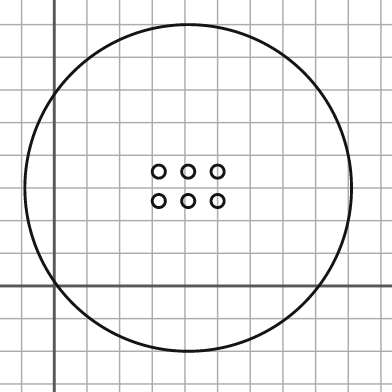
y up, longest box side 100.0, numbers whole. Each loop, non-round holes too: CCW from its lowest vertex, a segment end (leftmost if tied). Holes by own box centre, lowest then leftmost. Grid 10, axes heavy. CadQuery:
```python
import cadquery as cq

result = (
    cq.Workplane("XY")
    .moveTo(41.0, 30.0)
    .circle(50.0)
    .moveTo(32.0, 26.0)
    .circle(2.0)
    .moveTo(41.0, 26.0)
    .circle(2.0)
    .moveTo(50.0, 26.0)
    .circle(2.0)
    .moveTo(32.0, 35.0)
    .circle(2.0)
    .moveTo(41.0, 35.0)
    .circle(2.0)
    .moveTo(50.0, 35.0)
    .circle(2.0)
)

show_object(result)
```